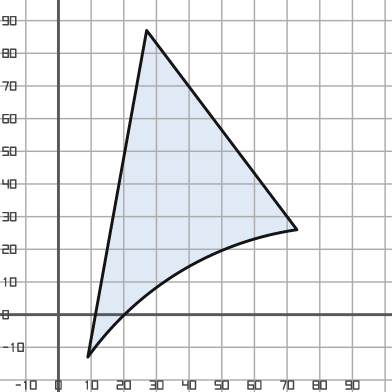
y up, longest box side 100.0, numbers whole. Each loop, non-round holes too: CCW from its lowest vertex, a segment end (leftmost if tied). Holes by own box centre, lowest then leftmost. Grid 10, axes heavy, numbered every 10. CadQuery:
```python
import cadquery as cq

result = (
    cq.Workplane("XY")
    .moveTo(9.0, -13.0)
    .threePointArc((37.0, 13.0), (73.0, 26.0))
    .lineTo(27.0, 87.0)
    .close()
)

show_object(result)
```